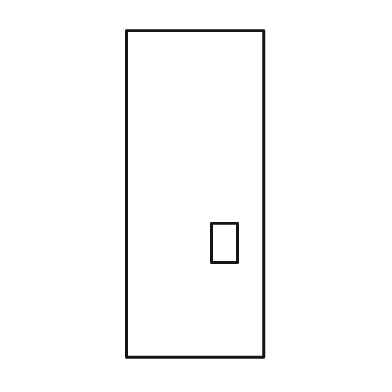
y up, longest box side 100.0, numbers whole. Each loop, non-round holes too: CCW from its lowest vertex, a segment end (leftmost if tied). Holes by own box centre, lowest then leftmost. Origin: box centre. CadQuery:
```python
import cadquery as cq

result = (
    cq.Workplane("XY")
    .moveTo(-21.0, -50.0)
    .lineTo(21.0, -50.0)
    .lineTo(21.0, 50.0)
    .lineTo(-21.0, 50.0)
    .close()
    .moveTo(5.0, -21.0)
    .lineTo(13.0, -21.0)
    .lineTo(13.0, -9.0)
    .lineTo(5.0, -9.0)
    .close()
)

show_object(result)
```